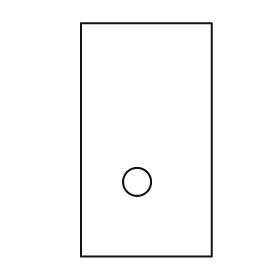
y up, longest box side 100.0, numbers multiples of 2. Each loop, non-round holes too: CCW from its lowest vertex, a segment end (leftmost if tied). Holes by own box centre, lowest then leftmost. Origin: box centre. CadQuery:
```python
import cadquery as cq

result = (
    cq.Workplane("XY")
    .moveTo(-28.0, -50.0)
    .lineTo(28.0, -50.0)
    .lineTo(28.0, 50.0)
    .lineTo(-28.0, 50.0)
    .close()
    .moveTo(-4.0, -18.0)
    .circle(6.0)
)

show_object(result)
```